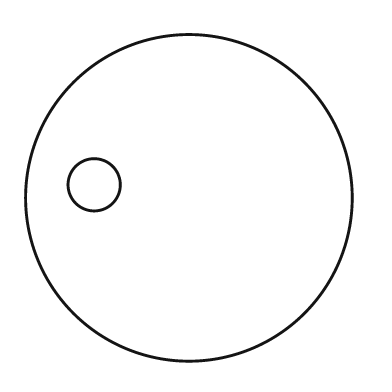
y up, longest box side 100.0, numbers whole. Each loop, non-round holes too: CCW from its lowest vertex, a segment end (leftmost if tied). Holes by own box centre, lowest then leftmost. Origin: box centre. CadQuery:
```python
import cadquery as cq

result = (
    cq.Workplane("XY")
    .moveTo(0.0, 0.0)
    .circle(50.0)
    .moveTo(-29.0, 4.0)
    .circle(8.0)
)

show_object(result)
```